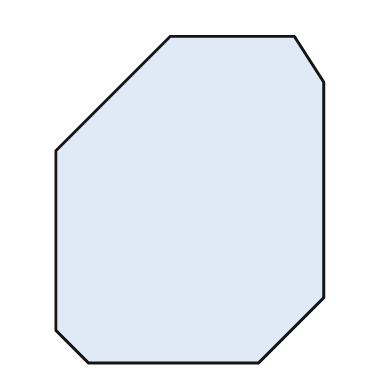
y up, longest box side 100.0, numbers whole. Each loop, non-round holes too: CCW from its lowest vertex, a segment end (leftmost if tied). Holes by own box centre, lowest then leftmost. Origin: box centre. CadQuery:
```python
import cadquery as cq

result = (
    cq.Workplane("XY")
    .moveTo(-31.0, -50.0)
    .lineTo(21.0, -50.0)
    .lineTo(41.0, -30.0)
    .lineTo(41.0, 36.0)
    .lineTo(32.0, 50.0)
    .lineTo(-6.0, 50.0)
    .lineTo(-41.0, 15.0)
    .lineTo(-41.0, -40.0)
    .close()
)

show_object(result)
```